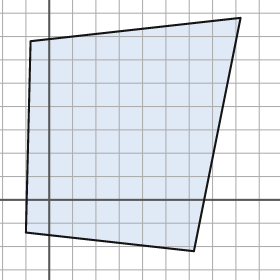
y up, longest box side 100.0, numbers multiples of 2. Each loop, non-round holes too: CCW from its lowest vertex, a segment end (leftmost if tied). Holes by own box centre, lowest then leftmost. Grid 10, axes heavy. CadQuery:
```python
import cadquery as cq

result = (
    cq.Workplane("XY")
    .moveTo(62.0, -22.0)
    .lineTo(82.0, 78.0)
    .lineTo(-8.0, 68.0)
    .lineTo(-10.0, -14.0)
    .close()
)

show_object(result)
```